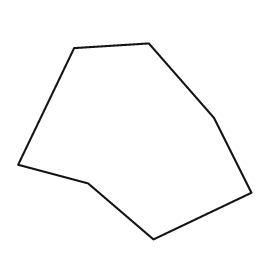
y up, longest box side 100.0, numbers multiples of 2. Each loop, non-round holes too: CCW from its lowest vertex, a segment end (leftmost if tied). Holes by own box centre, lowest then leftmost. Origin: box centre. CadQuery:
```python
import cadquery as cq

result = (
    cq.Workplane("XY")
    .moveTo(8.0, -42.0)
    .lineTo(50.0, -22.0)
    .lineTo(34.0, 10.0)
    .lineTo(6.0, 42.0)
    .lineTo(-26.0, 40.0)
    .lineTo(-50.0, -10.0)
    .lineTo(-20.0, -18.0)
    .close()
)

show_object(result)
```